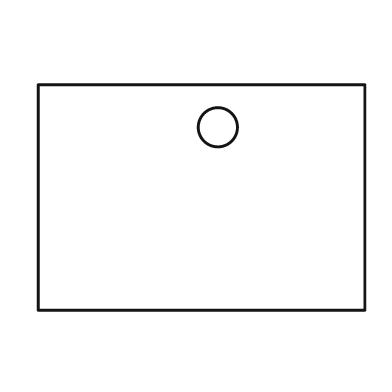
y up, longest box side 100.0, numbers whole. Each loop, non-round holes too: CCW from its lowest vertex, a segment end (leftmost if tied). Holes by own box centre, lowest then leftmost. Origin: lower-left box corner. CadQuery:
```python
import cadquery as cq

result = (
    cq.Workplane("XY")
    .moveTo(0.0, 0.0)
    .lineTo(100.0, 0.0)
    .lineTo(100.0, 69.0)
    .lineTo(0.0, 69.0)
    .close()
    .moveTo(55.0, 56.0)
    .circle(6.0)
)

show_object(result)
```